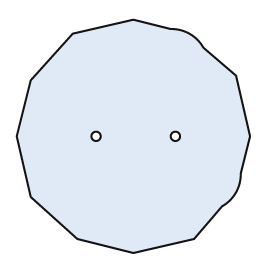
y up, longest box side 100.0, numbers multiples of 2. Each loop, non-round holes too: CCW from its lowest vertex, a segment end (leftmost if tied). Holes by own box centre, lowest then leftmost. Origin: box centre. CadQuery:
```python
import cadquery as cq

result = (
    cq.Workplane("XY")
    .moveTo(0.0, -50.0)
    .lineTo(26.0, -44.0)
    .lineTo(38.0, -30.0)
    .threePointArc((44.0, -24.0), (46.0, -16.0))
    .lineTo(50.0, 0.0)
    .lineTo(44.0, 26.0)
    .lineTo(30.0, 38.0)
    .threePointArc((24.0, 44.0), (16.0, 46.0))
    .lineTo(0.0, 50.0)
    .lineTo(-26.0, 44.0)
    .lineTo(-44.0, 24.0)
    .lineTo(-50.0, 0.0)
    .lineTo(-44.0, -26.0)
    .lineTo(-24.0, -44.0)
    .close()
    .moveTo(-16.0, 0.0)
    .circle(2.0)
    .moveTo(18.0, 0.0)
    .circle(2.0)
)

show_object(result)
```